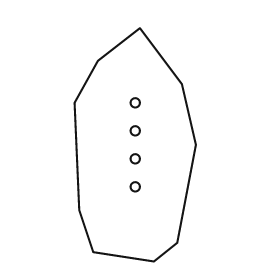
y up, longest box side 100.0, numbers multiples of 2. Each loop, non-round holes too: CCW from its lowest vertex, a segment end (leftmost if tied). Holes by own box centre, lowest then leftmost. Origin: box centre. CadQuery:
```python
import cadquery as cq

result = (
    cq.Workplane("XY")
    .moveTo(8.0, -50.0)
    .lineTo(18.0, -42.0)
    .lineTo(26.0, 0.0)
    .lineTo(20.0, 26.0)
    .lineTo(2.0, 50.0)
    .lineTo(-16.0, 36.0)
    .lineTo(-26.0, 18.0)
    .lineTo(-24.0, -28.0)
    .lineTo(-18.0, -46.0)
    .close()
    .moveTo(0.0, -18.0)
    .circle(2.0)
    .moveTo(0.0, -6.0)
    .circle(2.0)
    .moveTo(0.0, 6.0)
    .circle(2.0)
    .moveTo(0.0, 18.0)
    .circle(2.0)
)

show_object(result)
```